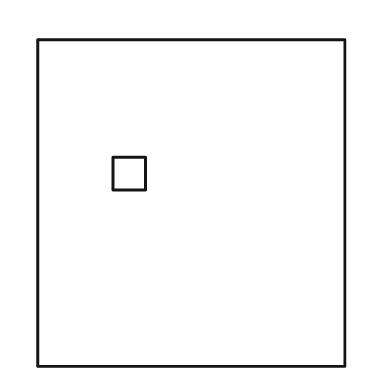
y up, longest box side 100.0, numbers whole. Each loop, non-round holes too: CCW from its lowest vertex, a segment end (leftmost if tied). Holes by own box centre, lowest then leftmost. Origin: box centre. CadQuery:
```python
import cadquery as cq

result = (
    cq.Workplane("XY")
    .moveTo(-47.0, -50.0)
    .lineTo(47.0, -50.0)
    .lineTo(47.0, 50.0)
    .lineTo(-47.0, 50.0)
    .close()
    .moveTo(-24.0, 4.0)
    .lineTo(-14.0, 4.0)
    .lineTo(-14.0, 14.0)
    .lineTo(-24.0, 14.0)
    .close()
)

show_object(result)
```